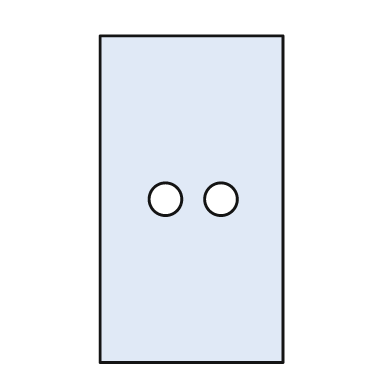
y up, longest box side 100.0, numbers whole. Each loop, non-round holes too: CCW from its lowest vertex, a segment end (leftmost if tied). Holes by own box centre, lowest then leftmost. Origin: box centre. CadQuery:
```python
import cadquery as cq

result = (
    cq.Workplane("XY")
    .moveTo(-28.0, -50.0)
    .lineTo(28.0, -50.0)
    .lineTo(28.0, 50.0)
    .lineTo(-28.0, 50.0)
    .close()
    .moveTo(-8.0, 0.0)
    .circle(5.0)
    .moveTo(9.0, 0.0)
    .circle(5.0)
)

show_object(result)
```